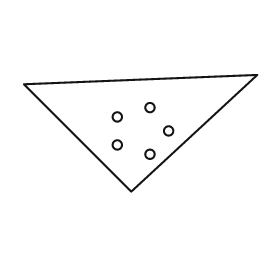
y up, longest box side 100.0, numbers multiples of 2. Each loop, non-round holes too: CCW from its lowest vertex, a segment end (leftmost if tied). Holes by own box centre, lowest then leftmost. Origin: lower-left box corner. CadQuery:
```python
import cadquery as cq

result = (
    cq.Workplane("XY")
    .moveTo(46.0, 0.0)
    .lineTo(100.0, 50.0)
    .lineTo(0.0, 46.0)
    .close()
    .moveTo(54.0, 16.0)
    .circle(2.0)
    .moveTo(40.0, 20.0)
    .circle(2.0)
    .moveTo(62.0, 26.0)
    .circle(2.0)
    .moveTo(40.0, 32.0)
    .circle(2.0)
    .moveTo(54.0, 36.0)
    .circle(2.0)
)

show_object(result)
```